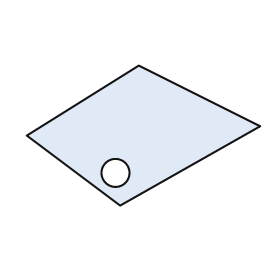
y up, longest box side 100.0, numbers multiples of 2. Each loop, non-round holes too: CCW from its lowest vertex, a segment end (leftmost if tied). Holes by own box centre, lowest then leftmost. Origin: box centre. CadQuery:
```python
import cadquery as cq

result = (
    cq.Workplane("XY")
    .moveTo(-10.0, -30.0)
    .lineTo(50.0, 4.0)
    .lineTo(-2.0, 30.0)
    .lineTo(-50.0, 0.0)
    .close()
    .moveTo(-12.0, -16.0)
    .circle(6.0)
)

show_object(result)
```